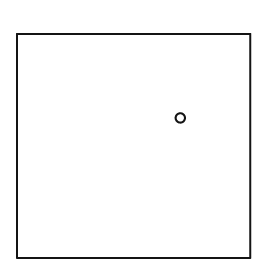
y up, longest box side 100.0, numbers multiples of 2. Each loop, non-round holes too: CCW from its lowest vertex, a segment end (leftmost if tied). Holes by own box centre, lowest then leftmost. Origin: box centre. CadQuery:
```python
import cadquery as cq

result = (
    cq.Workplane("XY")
    .moveTo(-50.0, -48.0)
    .lineTo(50.0, -48.0)
    .lineTo(50.0, 48.0)
    .lineTo(-50.0, 48.0)
    .close()
    .moveTo(20.0, 12.0)
    .circle(2.0)
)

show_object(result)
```